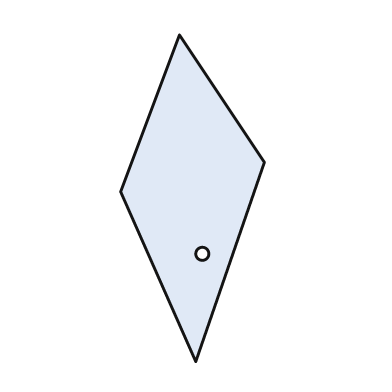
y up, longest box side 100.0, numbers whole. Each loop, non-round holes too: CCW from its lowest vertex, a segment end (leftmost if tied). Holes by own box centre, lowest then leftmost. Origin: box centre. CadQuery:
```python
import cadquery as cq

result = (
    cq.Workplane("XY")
    .moveTo(1.0, -50.0)
    .lineTo(22.0, 11.0)
    .lineTo(-4.0, 50.0)
    .lineTo(-22.0, 2.0)
    .close()
    .moveTo(3.0, -17.0)
    .circle(2.0)
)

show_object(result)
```